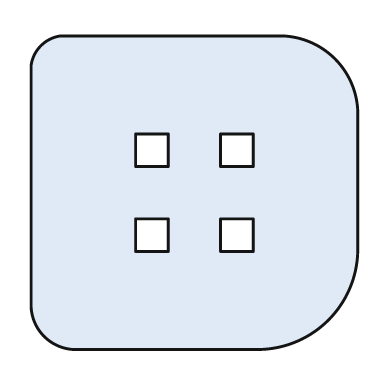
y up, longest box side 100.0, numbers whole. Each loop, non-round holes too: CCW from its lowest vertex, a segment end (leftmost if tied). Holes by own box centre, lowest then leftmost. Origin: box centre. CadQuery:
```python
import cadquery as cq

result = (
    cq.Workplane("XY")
    .moveTo(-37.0, -48.0)
    .lineTo(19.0, -48.0)
    .threePointArc((41.0, -39.0), (50.0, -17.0))
    .lineTo(50.0, 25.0)
    .threePointArc((43.0, 41.0), (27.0, 48.0))
    .lineTo(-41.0, 48.0)
    .threePointArc((-47.0, 45.0), (-50.0, 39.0))
    .lineTo(-50.0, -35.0)
    .threePointArc((-46.0, -44.0), (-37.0, -48.0))
    .close()
    .moveTo(-18.0, -18.0)
    .lineTo(-8.0, -18.0)
    .lineTo(-8.0, -8.0)
    .lineTo(-18.0, -8.0)
    .close()
    .moveTo(8.0, -18.0)
    .lineTo(18.0, -18.0)
    .lineTo(18.0, -8.0)
    .lineTo(8.0, -8.0)
    .close()
    .moveTo(-18.0, 8.0)
    .lineTo(-8.0, 8.0)
    .lineTo(-8.0, 18.0)
    .lineTo(-18.0, 18.0)
    .close()
    .moveTo(8.0, 8.0)
    .lineTo(18.0, 8.0)
    .lineTo(18.0, 18.0)
    .lineTo(8.0, 18.0)
    .close()
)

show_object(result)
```